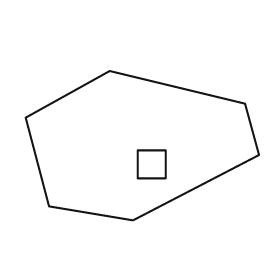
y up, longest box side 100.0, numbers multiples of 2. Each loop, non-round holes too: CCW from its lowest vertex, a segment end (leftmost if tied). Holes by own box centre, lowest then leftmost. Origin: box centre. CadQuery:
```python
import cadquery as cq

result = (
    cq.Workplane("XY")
    .moveTo(-4.0, -32.0)
    .lineTo(50.0, -4.0)
    .lineTo(44.0, 18.0)
    .lineTo(-14.0, 32.0)
    .lineTo(-50.0, 12.0)
    .lineTo(-40.0, -26.0)
    .close()
    .moveTo(-2.0, -14.0)
    .lineTo(10.0, -14.0)
    .lineTo(10.0, -2.0)
    .lineTo(-2.0, -2.0)
    .close()
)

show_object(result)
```